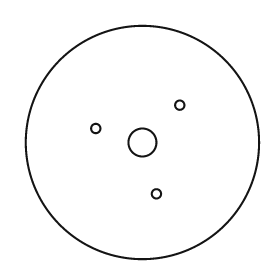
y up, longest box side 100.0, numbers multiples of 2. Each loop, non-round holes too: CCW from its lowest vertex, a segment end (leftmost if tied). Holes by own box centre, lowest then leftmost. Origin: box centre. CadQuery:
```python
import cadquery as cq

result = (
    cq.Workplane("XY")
    .moveTo(0.0, 0.0)
    .circle(50.0)
    .moveTo(6.0, -22.0)
    .circle(2.0)
    .moveTo(0.0, 0.0)
    .circle(6.0)
    .moveTo(-20.0, 6.0)
    .circle(2.0)
    .moveTo(16.0, 16.0)
    .circle(2.0)
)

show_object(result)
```